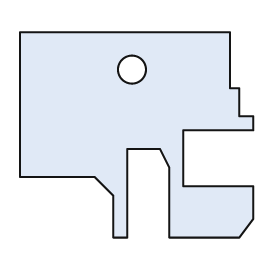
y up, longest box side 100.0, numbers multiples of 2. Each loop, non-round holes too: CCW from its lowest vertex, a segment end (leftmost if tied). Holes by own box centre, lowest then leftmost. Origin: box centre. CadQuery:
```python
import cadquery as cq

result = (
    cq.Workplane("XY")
    .moveTo(-10.0, -44.0)
    .lineTo(-4.0, -44.0)
    .lineTo(-4.0, -6.0)
    .lineTo(10.0, -6.0)
    .lineTo(14.0, -14.0)
    .lineTo(14.0, -44.0)
    .lineTo(44.0, -44.0)
    .lineTo(50.0, -36.0)
    .lineTo(50.0, -22.0)
    .lineTo(20.0, -22.0)
    .lineTo(20.0, 2.0)
    .lineTo(50.0, 2.0)
    .lineTo(50.0, 8.0)
    .lineTo(44.0, 8.0)
    .lineTo(44.0, 20.0)
    .lineTo(40.0, 20.0)
    .lineTo(40.0, 44.0)
    .lineTo(-50.0, 44.0)
    .lineTo(-50.0, -18.0)
    .lineTo(-18.0, -18.0)
    .lineTo(-10.0, -26.0)
    .close()
    .moveTo(-2.0, 28.0)
    .circle(6.0)
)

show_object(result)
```